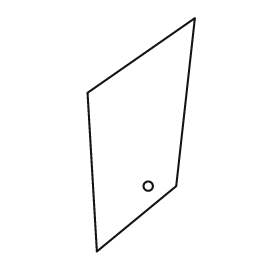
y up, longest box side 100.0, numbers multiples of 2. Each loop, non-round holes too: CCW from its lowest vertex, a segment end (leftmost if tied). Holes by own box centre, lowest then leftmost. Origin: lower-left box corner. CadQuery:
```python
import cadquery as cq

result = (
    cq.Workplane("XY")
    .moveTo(4.0, 0.0)
    .lineTo(38.0, 28.0)
    .lineTo(46.0, 100.0)
    .lineTo(0.0, 68.0)
    .close()
    .moveTo(26.0, 28.0)
    .circle(2.0)
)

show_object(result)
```